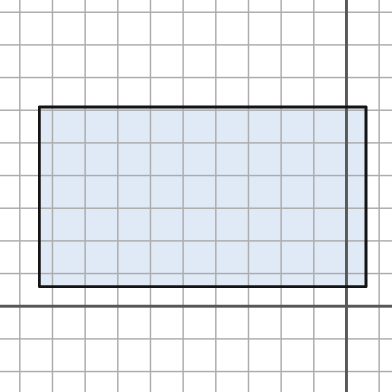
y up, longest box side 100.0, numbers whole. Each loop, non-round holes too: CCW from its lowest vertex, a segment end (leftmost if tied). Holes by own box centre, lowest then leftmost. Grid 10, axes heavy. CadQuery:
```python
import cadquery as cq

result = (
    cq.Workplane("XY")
    .moveTo(-94.0, 6.0)
    .lineTo(6.0, 6.0)
    .lineTo(6.0, 61.0)
    .lineTo(-94.0, 61.0)
    .close()
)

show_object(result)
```